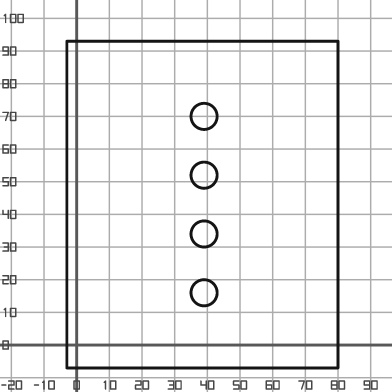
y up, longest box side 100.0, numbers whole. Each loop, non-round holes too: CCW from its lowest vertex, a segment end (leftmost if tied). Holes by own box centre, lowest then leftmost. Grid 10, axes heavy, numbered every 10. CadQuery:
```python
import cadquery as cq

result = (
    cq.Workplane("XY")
    .moveTo(-3.0, -7.0)
    .lineTo(80.0, -7.0)
    .lineTo(80.0, 93.0)
    .lineTo(-3.0, 93.0)
    .close()
    .moveTo(39.0, 16.0)
    .circle(4.0)
    .moveTo(39.0, 34.0)
    .circle(4.0)
    .moveTo(39.0, 52.0)
    .circle(4.0)
    .moveTo(39.0, 70.0)
    .circle(4.0)
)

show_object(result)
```